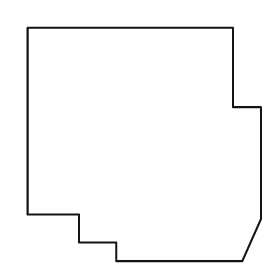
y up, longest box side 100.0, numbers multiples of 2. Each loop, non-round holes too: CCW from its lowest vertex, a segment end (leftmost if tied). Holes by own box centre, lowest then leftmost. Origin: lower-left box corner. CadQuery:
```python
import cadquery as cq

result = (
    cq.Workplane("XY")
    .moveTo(38.0, 0.0)
    .lineTo(92.0, 0.0)
    .lineTo(100.0, 18.0)
    .lineTo(100.0, 66.0)
    .lineTo(88.0, 66.0)
    .lineTo(88.0, 100.0)
    .lineTo(0.0, 100.0)
    .lineTo(0.0, 20.0)
    .lineTo(22.0, 20.0)
    .lineTo(22.0, 8.0)
    .lineTo(38.0, 8.0)
    .close()
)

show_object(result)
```